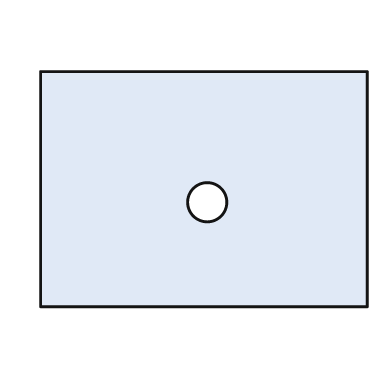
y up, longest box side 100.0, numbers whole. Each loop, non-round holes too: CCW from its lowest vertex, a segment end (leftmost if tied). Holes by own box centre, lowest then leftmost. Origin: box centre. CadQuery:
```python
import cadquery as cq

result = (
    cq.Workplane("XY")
    .moveTo(-50.0, -36.0)
    .lineTo(50.0, -36.0)
    .lineTo(50.0, 36.0)
    .lineTo(-50.0, 36.0)
    .close()
    .moveTo(1.0, -4.0)
    .circle(6.0)
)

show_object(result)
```